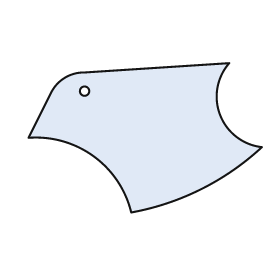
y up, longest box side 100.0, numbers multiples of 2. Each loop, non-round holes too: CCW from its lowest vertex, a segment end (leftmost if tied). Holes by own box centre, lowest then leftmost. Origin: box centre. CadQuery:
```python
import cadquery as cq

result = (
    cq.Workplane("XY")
    .moveTo(-6.0, -32.0)
    .threePointArc((24.0, -22.0), (50.0, -4.0))
    .threePointArc((32.0, 10.0), (36.0, 32.0))
    .lineTo(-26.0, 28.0)
    .threePointArc((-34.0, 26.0), (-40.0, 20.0))
    .lineTo(-50.0, 0.0)
    .threePointArc((-22.0, -8.0), (-6.0, -32.0))
    .close()
    .moveTo(-26.0, 20.0)
    .circle(2.0)
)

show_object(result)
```